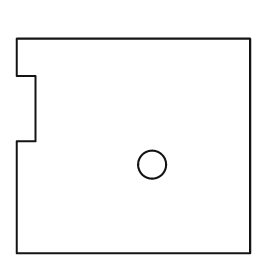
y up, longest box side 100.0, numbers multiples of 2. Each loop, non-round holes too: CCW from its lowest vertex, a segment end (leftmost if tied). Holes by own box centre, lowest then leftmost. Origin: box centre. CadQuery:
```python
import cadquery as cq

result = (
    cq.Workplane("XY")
    .moveTo(-50.0, -46.0)
    .lineTo(50.0, -46.0)
    .lineTo(50.0, 46.0)
    .lineTo(-50.0, 46.0)
    .lineTo(-50.0, 30.0)
    .lineTo(-42.0, 30.0)
    .lineTo(-42.0, 2.0)
    .lineTo(-50.0, 2.0)
    .close()
    .moveTo(8.0, -8.0)
    .circle(6.0)
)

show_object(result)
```